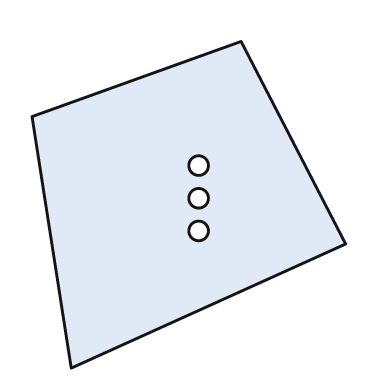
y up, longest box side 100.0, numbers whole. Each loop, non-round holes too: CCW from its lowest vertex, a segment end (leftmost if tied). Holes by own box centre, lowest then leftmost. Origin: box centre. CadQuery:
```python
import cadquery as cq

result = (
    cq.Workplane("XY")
    .moveTo(-36.0, -50.0)
    .lineTo(48.0, -12.0)
    .lineTo(16.0, 50.0)
    .lineTo(-48.0, 27.0)
    .close()
    .moveTo(3.0, -8.0)
    .circle(3.0)
    .moveTo(3.0, 2.0)
    .circle(3.0)
    .moveTo(3.0, 12.0)
    .circle(3.0)
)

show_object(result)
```